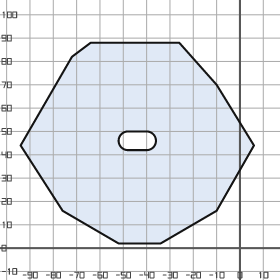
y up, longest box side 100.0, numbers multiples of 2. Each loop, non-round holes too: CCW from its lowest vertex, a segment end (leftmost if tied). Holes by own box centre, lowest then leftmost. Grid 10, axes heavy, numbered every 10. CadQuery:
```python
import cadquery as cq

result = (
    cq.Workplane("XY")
    .moveTo(-52.0, 2.0)
    .lineTo(-34.0, 2.0)
    .lineTo(-10.0, 16.0)
    .lineTo(6.0, 44.0)
    .lineTo(-10.0, 70.0)
    .lineTo(-26.0, 88.0)
    .lineTo(-64.0, 88.0)
    .lineTo(-72.0, 82.0)
    .lineTo(-94.0, 44.0)
    .lineTo(-76.0, 16.0)
    .close()
    .moveTo(-48.0, 42.0)
    .lineTo(-40.0, 42.0)
    .threePointArc((-36.0, 46.0), (-40.0, 50.0))
    .lineTo(-48.0, 50.0)
    .threePointArc((-52.0, 46.0), (-48.0, 42.0))
    .close()
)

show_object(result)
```